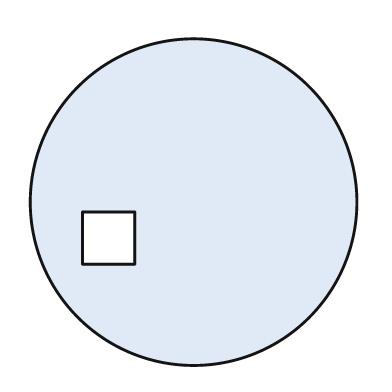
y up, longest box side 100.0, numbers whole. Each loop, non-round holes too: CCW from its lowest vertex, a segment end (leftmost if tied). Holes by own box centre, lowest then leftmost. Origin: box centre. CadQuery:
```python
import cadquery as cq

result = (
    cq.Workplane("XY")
    .moveTo(0.0, 0.0)
    .circle(50.0)
    .moveTo(-34.0, -19.0)
    .lineTo(-18.0, -19.0)
    .lineTo(-18.0, -3.0)
    .lineTo(-34.0, -3.0)
    .close()
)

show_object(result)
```